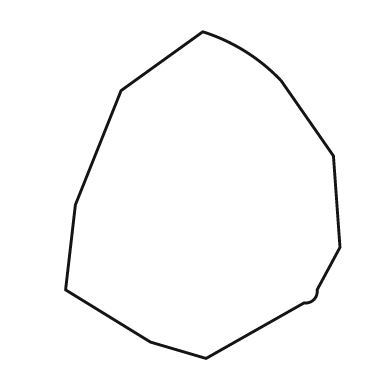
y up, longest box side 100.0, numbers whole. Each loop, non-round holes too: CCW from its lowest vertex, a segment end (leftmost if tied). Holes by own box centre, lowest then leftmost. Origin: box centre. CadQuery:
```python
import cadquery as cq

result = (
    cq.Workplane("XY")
    .moveTo(1.0, -50.0)
    .lineTo(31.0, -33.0)
    .threePointArc((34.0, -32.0), (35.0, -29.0))
    .lineTo(42.0, -16.0)
    .lineTo(40.0, 12.0)
    .lineTo(24.0, 35.0)
    .threePointArc((13.0, 44.0), (0.0, 50.0))
    .lineTo(-25.0, 32.0)
    .lineTo(-39.0, -3.0)
    .lineTo(-42.0, -29.0)
    .lineTo(-16.0, -45.0)
    .close()
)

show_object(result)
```